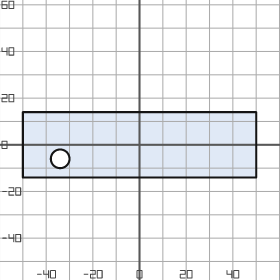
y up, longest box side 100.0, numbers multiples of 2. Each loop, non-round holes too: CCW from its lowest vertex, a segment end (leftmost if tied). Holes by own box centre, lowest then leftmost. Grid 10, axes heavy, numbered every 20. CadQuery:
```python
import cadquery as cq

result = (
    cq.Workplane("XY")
    .moveTo(-50.0, -14.0)
    .lineTo(50.0, -14.0)
    .lineTo(50.0, 14.0)
    .lineTo(-50.0, 14.0)
    .close()
    .moveTo(-34.0, -6.0)
    .circle(4.0)
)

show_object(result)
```